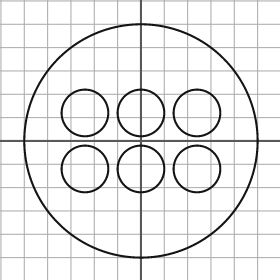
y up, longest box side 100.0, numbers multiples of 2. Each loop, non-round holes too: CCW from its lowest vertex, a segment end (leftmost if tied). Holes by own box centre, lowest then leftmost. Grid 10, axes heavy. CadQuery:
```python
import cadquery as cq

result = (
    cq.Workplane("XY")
    .moveTo(0.0, 0.0)
    .circle(50.0)
    .moveTo(-24.0, -12.0)
    .circle(10.0)
    .moveTo(0.0, -12.0)
    .circle(10.0)
    .moveTo(24.0, -12.0)
    .circle(10.0)
    .moveTo(-24.0, 12.0)
    .circle(10.0)
    .moveTo(0.0, 12.0)
    .circle(10.0)
    .moveTo(24.0, 12.0)
    .circle(10.0)
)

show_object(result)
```